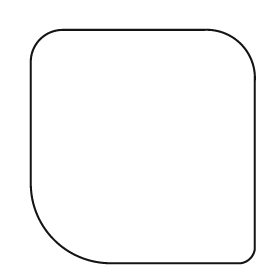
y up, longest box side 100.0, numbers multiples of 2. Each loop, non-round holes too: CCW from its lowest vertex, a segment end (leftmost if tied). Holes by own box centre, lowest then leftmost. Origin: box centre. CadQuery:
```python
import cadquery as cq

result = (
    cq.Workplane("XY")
    .moveTo(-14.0, -50.0)
    .lineTo(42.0, -50.0)
    .threePointArc((46.0, -48.0), (48.0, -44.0))
    .lineTo(48.0, 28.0)
    .threePointArc((42.0, 44.0), (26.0, 50.0))
    .lineTo(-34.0, 50.0)
    .threePointArc((-44.0, 46.0), (-48.0, 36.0))
    .lineTo(-48.0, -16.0)
    .threePointArc((-38.0, -40.0), (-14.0, -50.0))
    .close()
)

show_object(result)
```